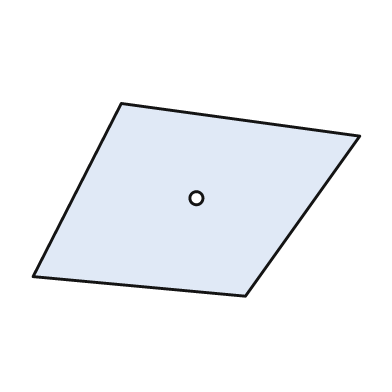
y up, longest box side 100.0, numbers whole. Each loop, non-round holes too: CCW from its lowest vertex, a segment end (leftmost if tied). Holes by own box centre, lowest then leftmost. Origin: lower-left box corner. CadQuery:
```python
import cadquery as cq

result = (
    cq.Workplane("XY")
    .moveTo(65.0, 0.0)
    .lineTo(100.0, 49.0)
    .lineTo(27.0, 59.0)
    .lineTo(0.0, 6.0)
    .close()
    .moveTo(50.0, 30.0)
    .circle(2.0)
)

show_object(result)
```